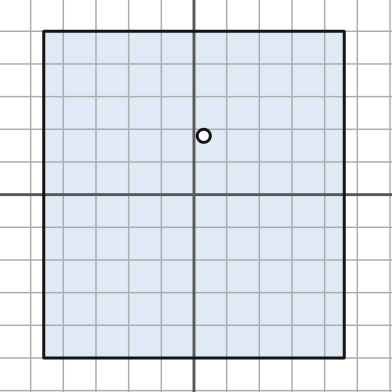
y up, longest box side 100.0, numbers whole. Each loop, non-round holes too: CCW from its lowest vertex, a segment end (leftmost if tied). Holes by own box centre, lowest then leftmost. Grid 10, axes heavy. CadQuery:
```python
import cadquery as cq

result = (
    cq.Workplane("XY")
    .moveTo(-46.0, -50.0)
    .lineTo(46.0, -50.0)
    .lineTo(46.0, 50.0)
    .lineTo(-46.0, 50.0)
    .close()
    .moveTo(3.0, 18.0)
    .circle(2.0)
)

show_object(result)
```